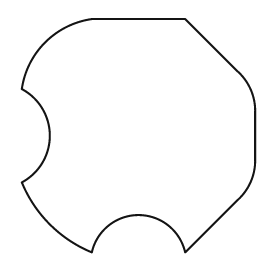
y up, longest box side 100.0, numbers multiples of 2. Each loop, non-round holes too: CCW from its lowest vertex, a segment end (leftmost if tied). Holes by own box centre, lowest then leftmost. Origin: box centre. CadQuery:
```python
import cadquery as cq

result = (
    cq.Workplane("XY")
    .moveTo(-20.0, -50.0)
    .threePointArc((0.0, -34.0), (20.0, -50.0))
    .lineTo(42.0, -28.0)
    .threePointArc((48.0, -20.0), (50.0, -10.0))
    .lineTo(50.0, 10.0)
    .threePointArc((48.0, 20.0), (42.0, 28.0))
    .lineTo(20.0, 50.0)
    .lineTo(-20.0, 50.0)
    .threePointArc((-40.0, 40.0), (-50.0, 20.0))
    .threePointArc((-38.0, 0.0), (-50.0, -20.0))
    .threePointArc((-38.0, -38.0), (-20.0, -50.0))
    .close()
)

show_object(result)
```